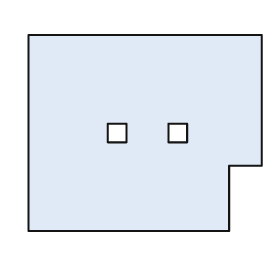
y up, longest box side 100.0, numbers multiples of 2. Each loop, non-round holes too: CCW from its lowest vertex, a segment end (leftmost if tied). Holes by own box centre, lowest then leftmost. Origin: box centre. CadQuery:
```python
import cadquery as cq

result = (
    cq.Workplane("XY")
    .moveTo(-50.0, -42.0)
    .lineTo(36.0, -42.0)
    .lineTo(36.0, -14.0)
    .lineTo(50.0, -14.0)
    .lineTo(50.0, 42.0)
    .lineTo(-50.0, 42.0)
    .close()
    .moveTo(-16.0, -4.0)
    .lineTo(-8.0, -4.0)
    .lineTo(-8.0, 4.0)
    .lineTo(-16.0, 4.0)
    .close()
    .moveTo(10.0, -4.0)
    .lineTo(18.0, -4.0)
    .lineTo(18.0, 4.0)
    .lineTo(10.0, 4.0)
    .close()
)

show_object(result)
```